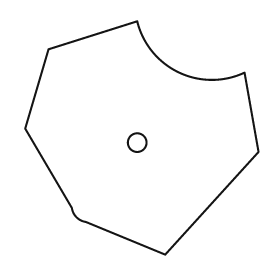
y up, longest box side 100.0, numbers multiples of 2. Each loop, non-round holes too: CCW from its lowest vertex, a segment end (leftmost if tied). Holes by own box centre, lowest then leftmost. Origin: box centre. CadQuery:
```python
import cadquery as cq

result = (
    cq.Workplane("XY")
    .moveTo(10.0, -50.0)
    .lineTo(50.0, -6.0)
    .lineTo(44.0, 28.0)
    .threePointArc((16.0, 28.0), (-2.0, 50.0))
    .lineTo(-40.0, 38.0)
    .lineTo(-50.0, 4.0)
    .lineTo(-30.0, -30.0)
    .threePointArc((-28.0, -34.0), (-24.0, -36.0))
    .close()
    .moveTo(-2.0, -2.0)
    .circle(4.0)
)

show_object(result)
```